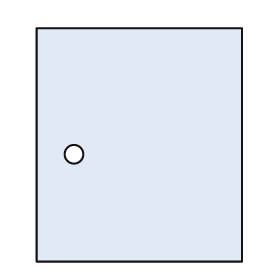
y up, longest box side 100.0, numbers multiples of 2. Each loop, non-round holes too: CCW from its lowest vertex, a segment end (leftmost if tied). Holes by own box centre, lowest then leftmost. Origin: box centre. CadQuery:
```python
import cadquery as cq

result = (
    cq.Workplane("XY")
    .moveTo(-44.0, -50.0)
    .lineTo(44.0, -50.0)
    .lineTo(44.0, 50.0)
    .lineTo(-44.0, 50.0)
    .close()
    .moveTo(-28.0, -4.0)
    .circle(4.0)
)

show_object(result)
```